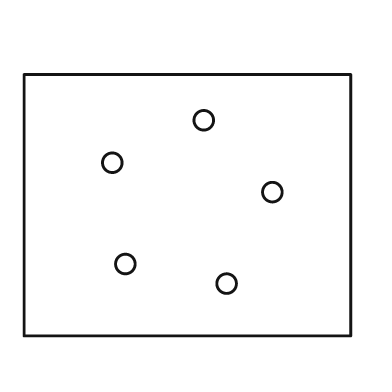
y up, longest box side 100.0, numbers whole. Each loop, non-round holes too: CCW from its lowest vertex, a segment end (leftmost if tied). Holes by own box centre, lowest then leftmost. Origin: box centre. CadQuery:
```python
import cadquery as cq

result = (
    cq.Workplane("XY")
    .moveTo(-50.0, -40.0)
    .lineTo(50.0, -40.0)
    .lineTo(50.0, 40.0)
    .lineTo(-50.0, 40.0)
    .close()
    .moveTo(12.0, -24.0)
    .circle(3.0)
    .moveTo(-19.0, -18.0)
    .circle(3.0)
    .moveTo(26.0, 4.0)
    .circle(3.0)
    .moveTo(-23.0, 13.0)
    .circle(3.0)
    .moveTo(5.0, 26.0)
    .circle(3.0)
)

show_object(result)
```